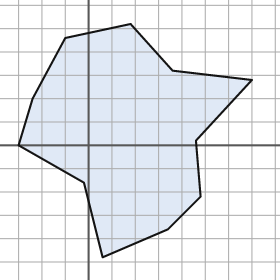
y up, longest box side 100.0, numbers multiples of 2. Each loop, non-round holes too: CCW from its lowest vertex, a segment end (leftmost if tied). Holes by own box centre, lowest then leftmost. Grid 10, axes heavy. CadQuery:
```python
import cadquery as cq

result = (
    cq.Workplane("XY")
    .moveTo(6.0, -48.0)
    .lineTo(34.0, -36.0)
    .lineTo(48.0, -22.0)
    .lineTo(46.0, 2.0)
    .lineTo(70.0, 28.0)
    .lineTo(36.0, 32.0)
    .lineTo(18.0, 52.0)
    .lineTo(-10.0, 46.0)
    .lineTo(-24.0, 20.0)
    .lineTo(-30.0, 0.0)
    .lineTo(-2.0, -16.0)
    .close()
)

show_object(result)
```